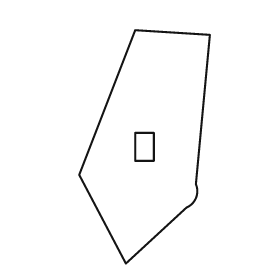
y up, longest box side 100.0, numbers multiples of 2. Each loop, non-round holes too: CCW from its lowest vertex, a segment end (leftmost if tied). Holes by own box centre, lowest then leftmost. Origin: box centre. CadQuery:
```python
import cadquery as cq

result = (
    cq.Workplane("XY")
    .moveTo(-8.0, -50.0)
    .lineTo(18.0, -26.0)
    .threePointArc((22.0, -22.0), (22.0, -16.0))
    .lineTo(28.0, 48.0)
    .lineTo(-4.0, 50.0)
    .lineTo(-28.0, -12.0)
    .close()
    .moveTo(-4.0, -6.0)
    .lineTo(4.0, -6.0)
    .lineTo(4.0, 6.0)
    .lineTo(-4.0, 6.0)
    .close()
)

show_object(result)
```